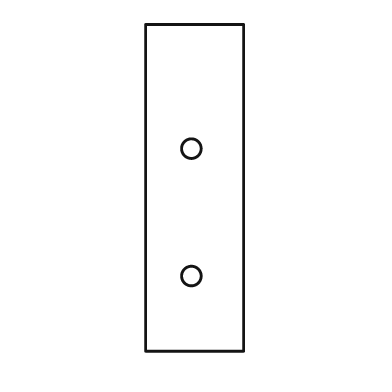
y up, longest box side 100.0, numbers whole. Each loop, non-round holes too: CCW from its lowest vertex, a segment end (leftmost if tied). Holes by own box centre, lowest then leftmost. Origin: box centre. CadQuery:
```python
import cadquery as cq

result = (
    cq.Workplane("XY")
    .moveTo(-15.0, -50.0)
    .lineTo(15.0, -50.0)
    .lineTo(15.0, 50.0)
    .lineTo(-15.0, 50.0)
    .close()
    .moveTo(-1.0, -27.0)
    .circle(3.0)
    .moveTo(-1.0, 12.0)
    .circle(3.0)
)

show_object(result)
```